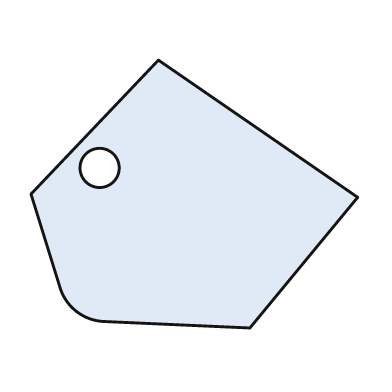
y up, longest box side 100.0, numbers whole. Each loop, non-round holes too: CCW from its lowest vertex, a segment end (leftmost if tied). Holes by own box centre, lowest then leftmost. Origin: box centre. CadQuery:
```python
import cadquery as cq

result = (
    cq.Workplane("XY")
    .moveTo(17.0, -41.0)
    .lineTo(50.0, -1.0)
    .lineTo(-11.0, 41.0)
    .lineTo(-50.0, 0.0)
    .lineTo(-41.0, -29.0)
    .threePointArc((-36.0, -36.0), (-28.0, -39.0))
    .close()
    .moveTo(-29.0, 8.0)
    .circle(6.0)
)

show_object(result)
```